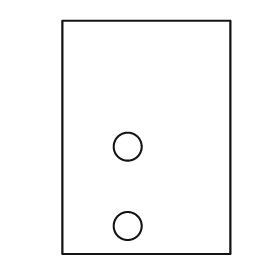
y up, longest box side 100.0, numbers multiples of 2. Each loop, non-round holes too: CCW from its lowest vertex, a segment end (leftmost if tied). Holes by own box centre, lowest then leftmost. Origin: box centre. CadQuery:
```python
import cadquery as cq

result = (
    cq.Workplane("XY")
    .moveTo(-36.0, -50.0)
    .lineTo(36.0, -50.0)
    .lineTo(36.0, 50.0)
    .lineTo(-36.0, 50.0)
    .close()
    .moveTo(-8.0, -38.0)
    .circle(6.0)
    .moveTo(-8.0, -4.0)
    .circle(6.0)
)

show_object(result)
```